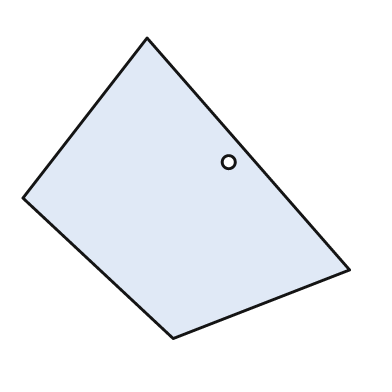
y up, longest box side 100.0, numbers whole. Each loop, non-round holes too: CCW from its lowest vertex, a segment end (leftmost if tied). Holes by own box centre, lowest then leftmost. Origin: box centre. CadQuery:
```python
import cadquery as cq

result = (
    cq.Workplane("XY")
    .moveTo(-4.0, -46.0)
    .lineTo(50.0, -25.0)
    .lineTo(-12.0, 46.0)
    .lineTo(-50.0, -3.0)
    .close()
    .moveTo(13.0, 8.0)
    .circle(2.0)
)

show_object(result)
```